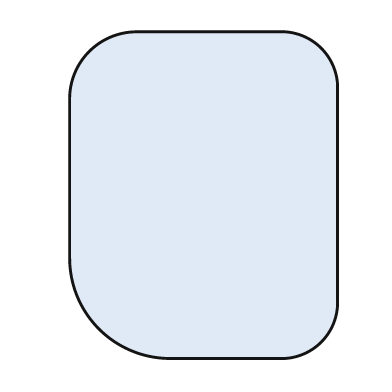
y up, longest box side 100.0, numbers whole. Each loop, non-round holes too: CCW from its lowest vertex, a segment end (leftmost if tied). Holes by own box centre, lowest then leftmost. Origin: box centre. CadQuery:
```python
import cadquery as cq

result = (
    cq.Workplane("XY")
    .moveTo(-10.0, -50.0)
    .lineTo(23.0, -50.0)
    .threePointArc((36.0, -45.0), (41.0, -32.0))
    .lineTo(41.0, 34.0)
    .threePointArc((36.0, 45.0), (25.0, 50.0))
    .lineTo(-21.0, 50.0)
    .threePointArc((-35.0, 44.0), (-41.0, 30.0))
    .lineTo(-41.0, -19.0)
    .threePointArc((-32.0, -41.0), (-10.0, -50.0))
    .close()
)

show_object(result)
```